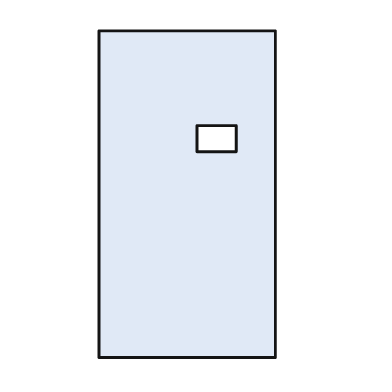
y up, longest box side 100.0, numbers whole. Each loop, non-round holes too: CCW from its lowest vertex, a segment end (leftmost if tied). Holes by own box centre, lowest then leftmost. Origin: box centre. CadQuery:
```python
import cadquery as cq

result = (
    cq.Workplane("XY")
    .moveTo(-27.0, -50.0)
    .lineTo(27.0, -50.0)
    .lineTo(27.0, 50.0)
    .lineTo(-27.0, 50.0)
    .close()
    .moveTo(3.0, 13.0)
    .lineTo(15.0, 13.0)
    .lineTo(15.0, 21.0)
    .lineTo(3.0, 21.0)
    .close()
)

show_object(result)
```